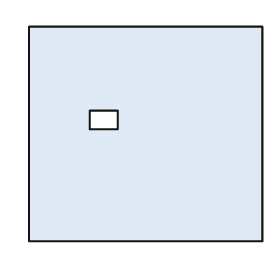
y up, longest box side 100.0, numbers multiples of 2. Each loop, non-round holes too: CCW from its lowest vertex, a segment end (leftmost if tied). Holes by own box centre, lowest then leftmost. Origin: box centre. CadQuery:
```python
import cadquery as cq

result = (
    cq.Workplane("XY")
    .moveTo(-50.0, -46.0)
    .lineTo(50.0, -46.0)
    .lineTo(50.0, 46.0)
    .lineTo(-50.0, 46.0)
    .close()
    .moveTo(-24.0, 2.0)
    .lineTo(-12.0, 2.0)
    .lineTo(-12.0, 10.0)
    .lineTo(-24.0, 10.0)
    .close()
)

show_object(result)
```